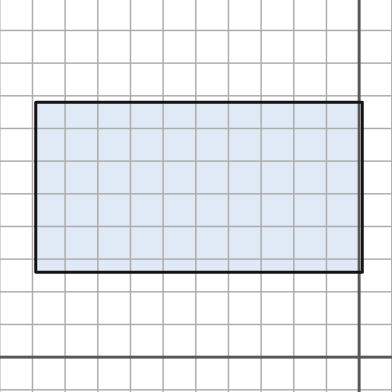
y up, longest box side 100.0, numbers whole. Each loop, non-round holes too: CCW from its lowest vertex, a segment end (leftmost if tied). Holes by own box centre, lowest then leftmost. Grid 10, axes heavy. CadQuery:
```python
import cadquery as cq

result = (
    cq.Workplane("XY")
    .moveTo(-99.0, 26.0)
    .lineTo(1.0, 26.0)
    .lineTo(1.0, 78.0)
    .lineTo(-99.0, 78.0)
    .close()
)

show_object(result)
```